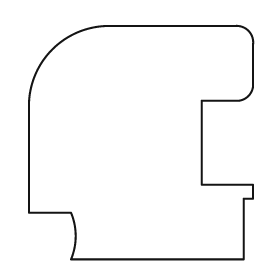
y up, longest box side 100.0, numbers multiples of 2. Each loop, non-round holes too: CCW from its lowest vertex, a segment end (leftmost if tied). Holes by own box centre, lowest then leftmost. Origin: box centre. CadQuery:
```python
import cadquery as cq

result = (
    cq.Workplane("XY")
    .moveTo(-30.0, -50.0)
    .lineTo(44.0, -50.0)
    .lineTo(44.0, -24.0)
    .lineTo(48.0, -24.0)
    .lineTo(48.0, -18.0)
    .lineTo(26.0, -18.0)
    .lineTo(26.0, 18.0)
    .lineTo(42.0, 18.0)
    .threePointArc((46.0, 20.0), (48.0, 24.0))
    .lineTo(48.0, 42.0)
    .threePointArc((46.0, 48.0), (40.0, 50.0))
    .lineTo(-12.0, 50.0)
    .threePointArc((-38.0, 40.0), (-48.0, 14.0))
    .lineTo(-48.0, -30.0)
    .lineTo(-30.0, -30.0)
    .threePointArc((-28.0, -40.0), (-30.0, -50.0))
    .close()
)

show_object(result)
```